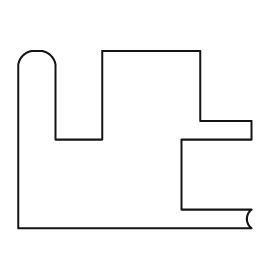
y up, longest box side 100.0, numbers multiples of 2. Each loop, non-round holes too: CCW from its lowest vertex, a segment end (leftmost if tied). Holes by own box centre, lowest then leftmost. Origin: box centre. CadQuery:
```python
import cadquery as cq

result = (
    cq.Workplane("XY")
    .moveTo(-50.0, -38.0)
    .lineTo(50.0, -38.0)
    .threePointArc((48.0, -34.0), (50.0, -30.0))
    .lineTo(20.0, -30.0)
    .lineTo(20.0, 0.0)
    .lineTo(50.0, 0.0)
    .lineTo(50.0, 8.0)
    .lineTo(28.0, 8.0)
    .lineTo(28.0, 38.0)
    .lineTo(-14.0, 38.0)
    .lineTo(-14.0, 0.0)
    .lineTo(-34.0, 0.0)
    .lineTo(-34.0, 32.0)
    .threePointArc((-36.0, 36.0), (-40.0, 38.0))
    .lineTo(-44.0, 38.0)
    .threePointArc((-48.0, 36.0), (-50.0, 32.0))
    .close()
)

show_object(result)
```